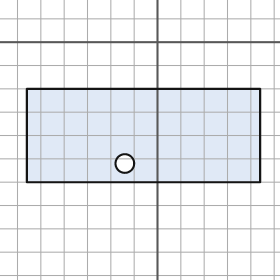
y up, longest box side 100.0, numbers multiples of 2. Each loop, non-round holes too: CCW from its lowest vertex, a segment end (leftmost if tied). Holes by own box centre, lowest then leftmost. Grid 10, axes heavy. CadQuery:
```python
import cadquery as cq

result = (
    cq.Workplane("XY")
    .moveTo(-56.0, -60.0)
    .lineTo(44.0, -60.0)
    .lineTo(44.0, -20.0)
    .lineTo(-56.0, -20.0)
    .close()
    .moveTo(-14.0, -52.0)
    .circle(4.0)
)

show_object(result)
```